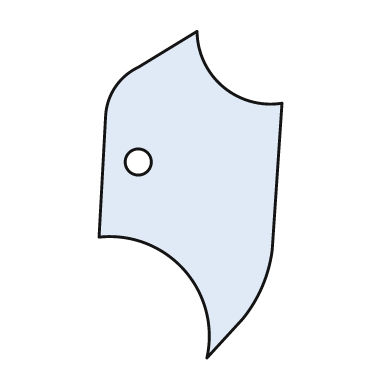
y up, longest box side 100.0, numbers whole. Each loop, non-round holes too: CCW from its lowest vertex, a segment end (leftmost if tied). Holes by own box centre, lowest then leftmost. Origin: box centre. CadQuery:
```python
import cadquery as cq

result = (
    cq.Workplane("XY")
    .moveTo(5.0, -50.0)
    .lineTo(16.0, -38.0)
    .threePointArc((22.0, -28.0), (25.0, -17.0))
    .lineTo(28.0, 28.0)
    .threePointArc((10.0, 33.0), (2.0, 50.0))
    .lineTo(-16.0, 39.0)
    .threePointArc((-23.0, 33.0), (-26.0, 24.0))
    .lineTo(-28.0, -13.0)
    .threePointArc((-2.0, -23.0), (5.0, -50.0))
    .close()
    .moveTo(-16.0, 10.0)
    .circle(4.0)
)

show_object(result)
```